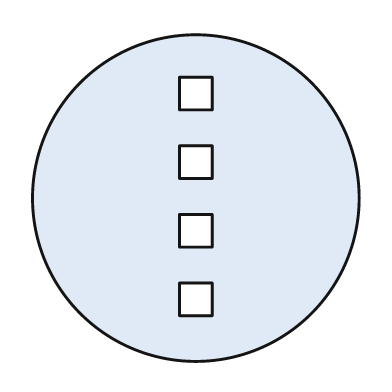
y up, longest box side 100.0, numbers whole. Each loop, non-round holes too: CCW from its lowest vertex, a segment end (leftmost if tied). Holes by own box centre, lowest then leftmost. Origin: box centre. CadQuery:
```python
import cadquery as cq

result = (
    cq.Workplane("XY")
    .moveTo(0.0, 0.0)
    .circle(50.0)
    .moveTo(-5.0, -36.0)
    .lineTo(5.0, -36.0)
    .lineTo(5.0, -26.0)
    .lineTo(-5.0, -26.0)
    .close()
    .moveTo(-5.0, -15.0)
    .lineTo(5.0, -15.0)
    .lineTo(5.0, -5.0)
    .lineTo(-5.0, -5.0)
    .close()
    .moveTo(-5.0, 6.0)
    .lineTo(5.0, 6.0)
    .lineTo(5.0, 16.0)
    .lineTo(-5.0, 16.0)
    .close()
    .moveTo(-5.0, 27.0)
    .lineTo(5.0, 27.0)
    .lineTo(5.0, 37.0)
    .lineTo(-5.0, 37.0)
    .close()
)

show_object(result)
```